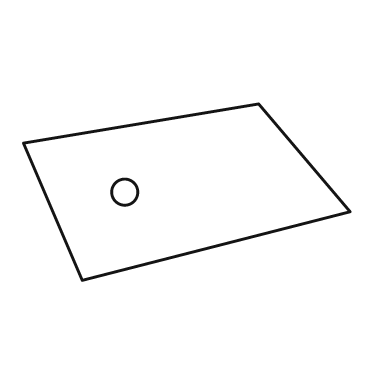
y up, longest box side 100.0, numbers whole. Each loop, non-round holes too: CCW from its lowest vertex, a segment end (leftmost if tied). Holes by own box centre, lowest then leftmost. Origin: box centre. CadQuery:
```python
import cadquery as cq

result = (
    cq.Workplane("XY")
    .moveTo(-32.0, -27.0)
    .lineTo(50.0, -6.0)
    .lineTo(22.0, 27.0)
    .lineTo(-50.0, 15.0)
    .close()
    .moveTo(-19.0, 0.0)
    .circle(4.0)
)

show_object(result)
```